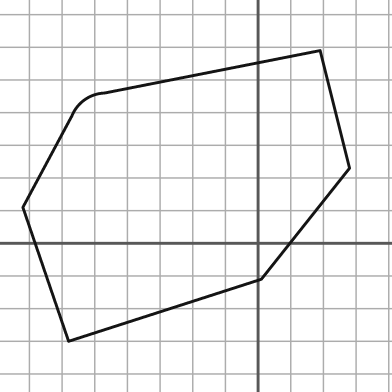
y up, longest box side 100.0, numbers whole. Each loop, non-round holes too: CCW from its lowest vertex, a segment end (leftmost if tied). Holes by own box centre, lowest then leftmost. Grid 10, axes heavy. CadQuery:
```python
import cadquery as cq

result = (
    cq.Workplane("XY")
    .moveTo(-58.0, -30.0)
    .lineTo(1.0, -11.0)
    .lineTo(28.0, 23.0)
    .lineTo(19.0, 59.0)
    .lineTo(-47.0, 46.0)
    .threePointArc((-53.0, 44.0), (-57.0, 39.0))
    .lineTo(-72.0, 11.0)
    .close()
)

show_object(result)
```